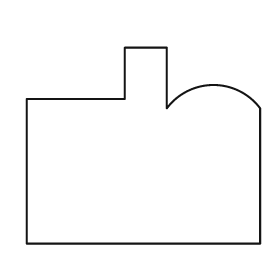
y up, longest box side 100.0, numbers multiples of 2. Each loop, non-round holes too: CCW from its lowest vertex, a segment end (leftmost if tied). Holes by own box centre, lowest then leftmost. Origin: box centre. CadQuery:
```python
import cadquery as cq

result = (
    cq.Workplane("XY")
    .moveTo(-50.0, -42.0)
    .lineTo(50.0, -42.0)
    .lineTo(50.0, 16.0)
    .threePointArc((30.0, 26.0), (10.0, 16.0))
    .lineTo(10.0, 42.0)
    .lineTo(-8.0, 42.0)
    .lineTo(-8.0, 20.0)
    .lineTo(-50.0, 20.0)
    .close()
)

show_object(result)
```